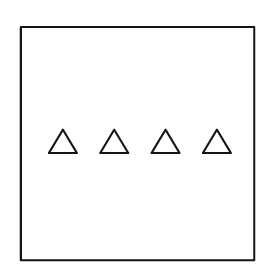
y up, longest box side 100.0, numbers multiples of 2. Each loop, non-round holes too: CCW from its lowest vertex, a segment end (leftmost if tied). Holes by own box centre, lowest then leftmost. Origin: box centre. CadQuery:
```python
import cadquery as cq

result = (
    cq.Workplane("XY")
    .moveTo(-50.0, -50.0)
    .lineTo(50.0, -50.0)
    .lineTo(50.0, 50.0)
    .lineTo(-50.0, 50.0)
    .close()
    .moveTo(-38.0, -4.0)
    .lineTo(-26.0, -4.0)
    .lineTo(-32.0, 6.0)
    .close()
    .moveTo(-16.0, -4.0)
    .lineTo(-4.0, -4.0)
    .lineTo(-10.0, 6.0)
    .close()
    .moveTo(6.0, -4.0)
    .lineTo(18.0, -4.0)
    .lineTo(12.0, 6.0)
    .close()
    .moveTo(28.0, -4.0)
    .lineTo(40.0, -4.0)
    .lineTo(34.0, 6.0)
    .close()
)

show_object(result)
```